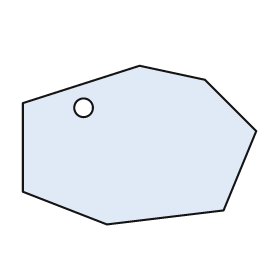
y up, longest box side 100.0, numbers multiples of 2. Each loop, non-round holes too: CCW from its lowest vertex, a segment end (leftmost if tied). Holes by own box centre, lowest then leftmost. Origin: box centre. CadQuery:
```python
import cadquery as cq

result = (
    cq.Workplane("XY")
    .moveTo(-14.0, -34.0)
    .lineTo(36.0, -28.0)
    .lineTo(50.0, 6.0)
    .lineTo(28.0, 28.0)
    .lineTo(0.0, 34.0)
    .lineTo(-50.0, 18.0)
    .lineTo(-50.0, -20.0)
    .close()
    .moveTo(-24.0, 16.0)
    .circle(4.0)
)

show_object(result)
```